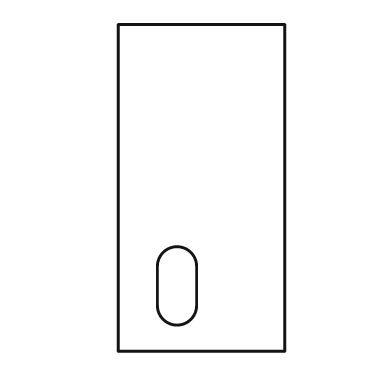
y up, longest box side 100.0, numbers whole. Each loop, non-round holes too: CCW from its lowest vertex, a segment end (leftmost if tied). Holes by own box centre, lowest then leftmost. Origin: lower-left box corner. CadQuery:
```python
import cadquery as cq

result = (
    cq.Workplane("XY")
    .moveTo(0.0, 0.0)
    .lineTo(51.0, 0.0)
    .lineTo(51.0, 100.0)
    .lineTo(0.0, 100.0)
    .close()
    .moveTo(12.0, 14.0)
    .threePointArc((18.0, 8.0), (24.0, 14.0))
    .lineTo(24.0, 26.0)
    .threePointArc((18.0, 32.0), (12.0, 26.0))
    .close()
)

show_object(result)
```